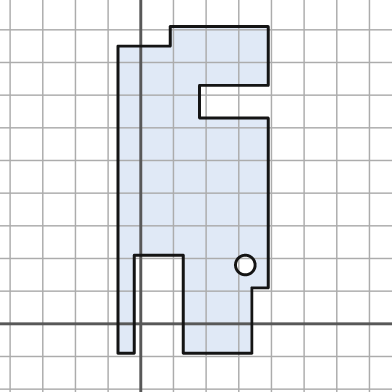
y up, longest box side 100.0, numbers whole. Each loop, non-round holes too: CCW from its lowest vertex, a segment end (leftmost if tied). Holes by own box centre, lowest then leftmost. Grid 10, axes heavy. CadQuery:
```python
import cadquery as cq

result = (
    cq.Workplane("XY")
    .moveTo(-7.0, -9.0)
    .lineTo(-2.0, -9.0)
    .lineTo(-2.0, 21.0)
    .lineTo(13.0, 21.0)
    .lineTo(13.0, -9.0)
    .lineTo(34.0, -9.0)
    .lineTo(34.0, 11.0)
    .lineTo(39.0, 11.0)
    .lineTo(39.0, 63.0)
    .lineTo(18.0, 63.0)
    .lineTo(18.0, 73.0)
    .lineTo(39.0, 73.0)
    .lineTo(39.0, 91.0)
    .lineTo(9.0, 91.0)
    .lineTo(9.0, 85.0)
    .lineTo(-7.0, 85.0)
    .close()
    .moveTo(32.0, 18.0)
    .circle(3.0)
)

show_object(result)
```